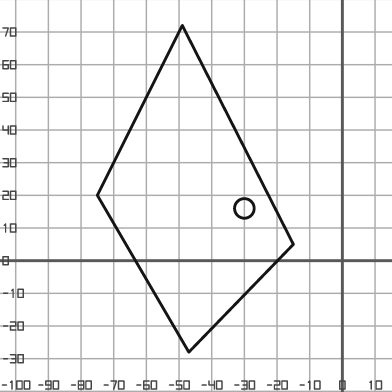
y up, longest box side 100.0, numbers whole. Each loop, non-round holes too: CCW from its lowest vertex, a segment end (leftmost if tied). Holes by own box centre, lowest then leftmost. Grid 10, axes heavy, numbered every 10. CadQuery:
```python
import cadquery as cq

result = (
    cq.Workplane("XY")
    .moveTo(-47.0, -28.0)
    .lineTo(-15.0, 5.0)
    .lineTo(-49.0, 72.0)
    .lineTo(-75.0, 20.0)
    .close()
    .moveTo(-30.0, 16.0)
    .circle(3.0)
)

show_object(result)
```